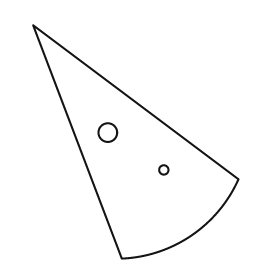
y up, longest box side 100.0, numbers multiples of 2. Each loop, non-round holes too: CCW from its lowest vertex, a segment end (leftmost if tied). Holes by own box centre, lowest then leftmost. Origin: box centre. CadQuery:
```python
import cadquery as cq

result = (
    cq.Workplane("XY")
    .moveTo(-6.0, -50.0)
    .threePointArc((24.0, -40.0), (44.0, -16.0))
    .lineTo(-44.0, 50.0)
    .close()
    .moveTo(12.0, -12.0)
    .circle(2.0)
    .moveTo(-12.0, 4.0)
    .circle(4.0)
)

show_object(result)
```